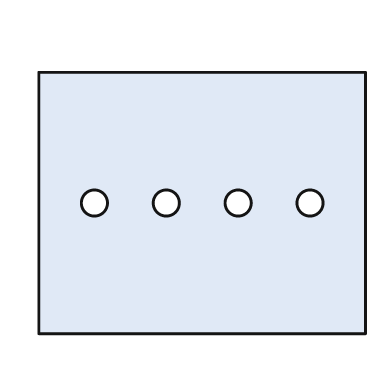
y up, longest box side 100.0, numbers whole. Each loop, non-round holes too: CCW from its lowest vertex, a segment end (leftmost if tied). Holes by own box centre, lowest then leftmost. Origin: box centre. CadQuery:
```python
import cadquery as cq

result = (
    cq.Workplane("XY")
    .moveTo(-50.0, -40.0)
    .lineTo(50.0, -40.0)
    .lineTo(50.0, 40.0)
    .lineTo(-50.0, 40.0)
    .close()
    .moveTo(-33.0, 0.0)
    .circle(4.0)
    .moveTo(-11.0, 0.0)
    .circle(4.0)
    .moveTo(11.0, 0.0)
    .circle(4.0)
    .moveTo(33.0, 0.0)
    .circle(4.0)
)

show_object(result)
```